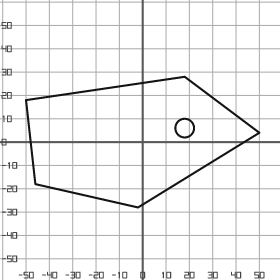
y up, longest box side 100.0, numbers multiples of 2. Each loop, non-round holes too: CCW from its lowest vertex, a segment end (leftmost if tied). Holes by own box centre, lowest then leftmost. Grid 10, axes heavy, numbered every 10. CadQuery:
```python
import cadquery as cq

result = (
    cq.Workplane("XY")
    .moveTo(-2.0, -28.0)
    .lineTo(50.0, 4.0)
    .lineTo(18.0, 28.0)
    .lineTo(-50.0, 18.0)
    .lineTo(-46.0, -18.0)
    .close()
    .moveTo(18.0, 6.0)
    .circle(4.0)
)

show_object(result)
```